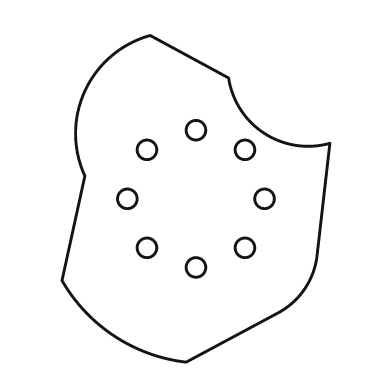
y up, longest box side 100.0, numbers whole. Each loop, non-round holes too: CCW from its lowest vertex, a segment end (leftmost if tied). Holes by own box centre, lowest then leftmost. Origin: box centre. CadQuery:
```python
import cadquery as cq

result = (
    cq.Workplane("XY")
    .moveTo(-3.0, -50.0)
    .lineTo(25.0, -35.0)
    .threePointArc((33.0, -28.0), (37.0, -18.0))
    .lineTo(41.0, 17.0)
    .threePointArc((21.0, 20.0), (10.0, 37.0))
    .lineTo(-14.0, 50.0)
    .threePointArc((-34.0, 33.0), (-34.0, 7.0))
    .lineTo(-41.0, -25.0)
    .threePointArc((-25.0, -42.0), (-3.0, -50.0))
    .close()
    .moveTo(0.0, -21.0)
    .circle(3.0)
    .moveTo(-15.0, -15.0)
    .circle(3.0)
    .moveTo(15.0, -15.0)
    .circle(3.0)
    .moveTo(-21.0, 0.0)
    .circle(3.0)
    .moveTo(21.0, 0.0)
    .circle(3.0)
    .moveTo(-15.0, 15.0)
    .circle(3.0)
    .moveTo(15.0, 15.0)
    .circle(3.0)
    .moveTo(0.0, 21.0)
    .circle(3.0)
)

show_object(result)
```